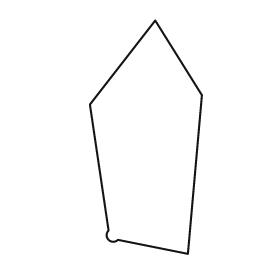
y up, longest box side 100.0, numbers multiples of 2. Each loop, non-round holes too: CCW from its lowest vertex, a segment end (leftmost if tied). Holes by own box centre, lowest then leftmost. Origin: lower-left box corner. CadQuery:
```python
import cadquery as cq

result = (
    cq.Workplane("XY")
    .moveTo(42.0, 0.0)
    .lineTo(48.0, 68.0)
    .lineTo(28.0, 100.0)
    .lineTo(0.0, 64.0)
    .lineTo(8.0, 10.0)
    .threePointArc((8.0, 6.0), (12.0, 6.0))
    .close()
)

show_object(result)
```